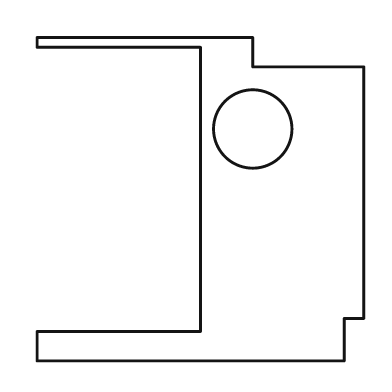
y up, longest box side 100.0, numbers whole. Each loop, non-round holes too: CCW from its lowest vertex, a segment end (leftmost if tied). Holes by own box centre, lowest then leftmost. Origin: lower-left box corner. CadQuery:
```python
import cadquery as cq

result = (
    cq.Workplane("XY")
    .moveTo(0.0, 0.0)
    .lineTo(94.0, 0.0)
    .lineTo(94.0, 13.0)
    .lineTo(100.0, 13.0)
    .lineTo(100.0, 90.0)
    .lineTo(66.0, 90.0)
    .lineTo(66.0, 99.0)
    .lineTo(0.0, 99.0)
    .lineTo(0.0, 96.0)
    .lineTo(50.0, 96.0)
    .lineTo(50.0, 9.0)
    .lineTo(0.0, 9.0)
    .close()
    .moveTo(66.0, 71.0)
    .circle(12.0)
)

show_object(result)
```